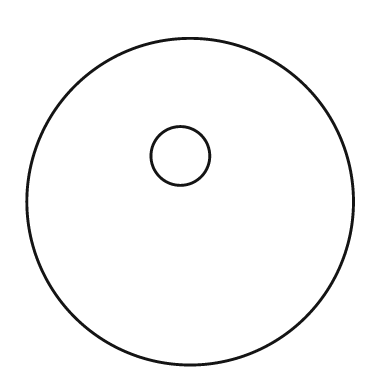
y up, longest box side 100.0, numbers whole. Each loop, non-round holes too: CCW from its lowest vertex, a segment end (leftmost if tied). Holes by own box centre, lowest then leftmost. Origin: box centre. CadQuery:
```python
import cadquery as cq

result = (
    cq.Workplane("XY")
    .moveTo(0.0, 0.0)
    .circle(50.0)
    .moveTo(-3.0, 14.0)
    .circle(9.0)
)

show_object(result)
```